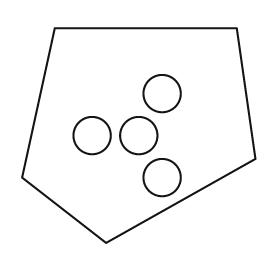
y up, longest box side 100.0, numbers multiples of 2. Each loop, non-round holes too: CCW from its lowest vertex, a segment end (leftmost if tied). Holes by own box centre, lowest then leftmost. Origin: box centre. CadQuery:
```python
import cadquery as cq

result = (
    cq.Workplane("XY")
    .moveTo(-14.0, -46.0)
    .lineTo(50.0, -10.0)
    .lineTo(42.0, 46.0)
    .lineTo(-36.0, 46.0)
    .lineTo(-50.0, -18.0)
    .close()
    .moveTo(10.0, -18.0)
    .circle(8.0)
    .moveTo(-20.0, 0.0)
    .circle(8.0)
    .moveTo(0.0, 0.0)
    .circle(8.0)
    .moveTo(10.0, 18.0)
    .circle(8.0)
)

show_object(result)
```